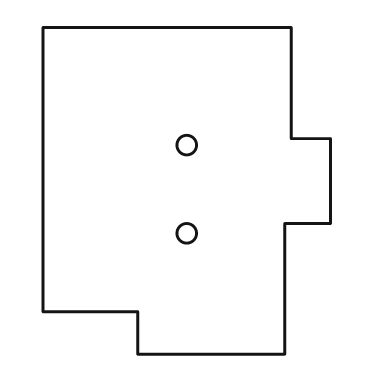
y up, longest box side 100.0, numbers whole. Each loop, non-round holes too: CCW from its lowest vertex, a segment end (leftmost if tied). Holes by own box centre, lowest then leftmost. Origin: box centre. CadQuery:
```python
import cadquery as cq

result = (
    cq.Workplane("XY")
    .moveTo(-15.0, -50.0)
    .lineTo(30.0, -50.0)
    .lineTo(30.0, -10.0)
    .lineTo(44.0, -10.0)
    .lineTo(44.0, 16.0)
    .lineTo(32.0, 16.0)
    .lineTo(32.0, 50.0)
    .lineTo(-44.0, 50.0)
    .lineTo(-44.0, -37.0)
    .lineTo(-15.0, -37.0)
    .close()
    .moveTo(0.0, -13.0)
    .circle(3.0)
    .moveTo(0.0, 14.0)
    .circle(3.0)
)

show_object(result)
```